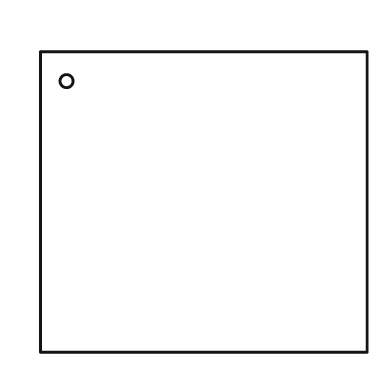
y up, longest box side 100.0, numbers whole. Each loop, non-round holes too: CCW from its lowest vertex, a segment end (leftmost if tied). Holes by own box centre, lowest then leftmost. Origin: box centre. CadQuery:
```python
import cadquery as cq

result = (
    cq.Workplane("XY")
    .moveTo(-50.0, -46.0)
    .lineTo(50.0, -46.0)
    .lineTo(50.0, 46.0)
    .lineTo(-50.0, 46.0)
    .close()
    .moveTo(-42.0, 37.0)
    .circle(2.0)
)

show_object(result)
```